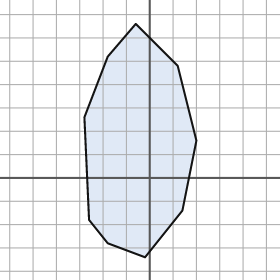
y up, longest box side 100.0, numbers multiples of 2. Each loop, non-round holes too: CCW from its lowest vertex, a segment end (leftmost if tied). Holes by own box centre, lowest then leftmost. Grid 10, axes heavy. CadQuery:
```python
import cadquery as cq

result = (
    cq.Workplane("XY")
    .moveTo(-2.0, -34.0)
    .lineTo(14.0, -14.0)
    .lineTo(20.0, 16.0)
    .lineTo(12.0, 48.0)
    .lineTo(-6.0, 66.0)
    .lineTo(-18.0, 52.0)
    .lineTo(-28.0, 26.0)
    .lineTo(-26.0, -18.0)
    .lineTo(-18.0, -28.0)
    .close()
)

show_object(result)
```